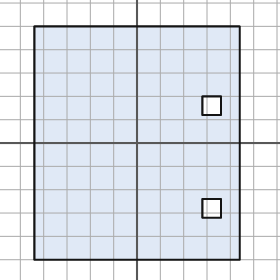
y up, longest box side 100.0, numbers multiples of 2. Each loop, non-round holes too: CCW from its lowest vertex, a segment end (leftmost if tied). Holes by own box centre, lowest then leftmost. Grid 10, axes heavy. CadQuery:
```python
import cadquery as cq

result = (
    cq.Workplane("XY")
    .moveTo(-44.0, -50.0)
    .lineTo(44.0, -50.0)
    .lineTo(44.0, 50.0)
    .lineTo(-44.0, 50.0)
    .close()
    .moveTo(28.0, -32.0)
    .lineTo(36.0, -32.0)
    .lineTo(36.0, -24.0)
    .lineTo(28.0, -24.0)
    .close()
    .moveTo(28.0, 12.0)
    .lineTo(36.0, 12.0)
    .lineTo(36.0, 20.0)
    .lineTo(28.0, 20.0)
    .close()
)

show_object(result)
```